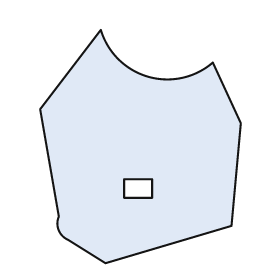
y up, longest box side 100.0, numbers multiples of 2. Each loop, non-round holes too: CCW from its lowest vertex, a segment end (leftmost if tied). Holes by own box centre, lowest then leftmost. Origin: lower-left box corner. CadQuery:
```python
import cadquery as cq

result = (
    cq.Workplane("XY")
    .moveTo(28.0, 0.0)
    .lineTo(82.0, 16.0)
    .lineTo(86.0, 60.0)
    .lineTo(74.0, 86.0)
    .threePointArc((46.0, 80.0), (26.0, 100.0))
    .lineTo(0.0, 66.0)
    .lineTo(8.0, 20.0)
    .threePointArc((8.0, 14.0), (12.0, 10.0))
    .close()
    .moveTo(36.0, 28.0)
    .lineTo(48.0, 28.0)
    .lineTo(48.0, 36.0)
    .lineTo(36.0, 36.0)
    .close()
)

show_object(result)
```